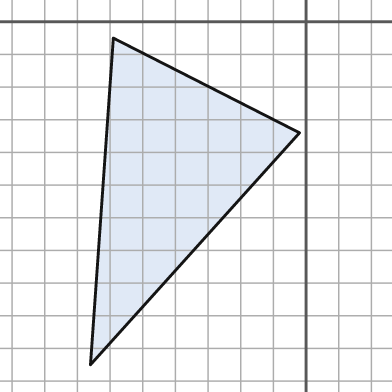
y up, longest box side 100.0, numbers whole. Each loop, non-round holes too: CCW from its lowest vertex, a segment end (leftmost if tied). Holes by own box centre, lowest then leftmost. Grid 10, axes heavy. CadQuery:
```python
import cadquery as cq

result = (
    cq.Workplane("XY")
    .moveTo(-66.0, -105.0)
    .lineTo(-2.0, -34.0)
    .lineTo(-59.0, -5.0)
    .close()
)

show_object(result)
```